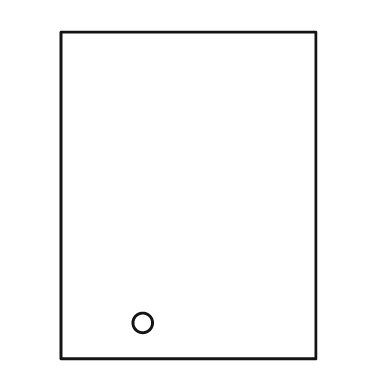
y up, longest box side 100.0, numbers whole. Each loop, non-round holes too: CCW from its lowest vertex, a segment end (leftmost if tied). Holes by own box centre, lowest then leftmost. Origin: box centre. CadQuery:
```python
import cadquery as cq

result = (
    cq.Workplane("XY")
    .moveTo(-39.0, -50.0)
    .lineTo(39.0, -50.0)
    .lineTo(39.0, 50.0)
    .lineTo(-39.0, 50.0)
    .close()
    .moveTo(-14.0, -39.0)
    .circle(3.0)
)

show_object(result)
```